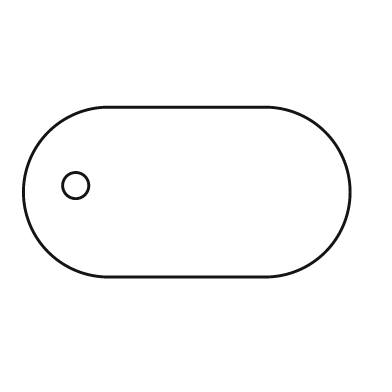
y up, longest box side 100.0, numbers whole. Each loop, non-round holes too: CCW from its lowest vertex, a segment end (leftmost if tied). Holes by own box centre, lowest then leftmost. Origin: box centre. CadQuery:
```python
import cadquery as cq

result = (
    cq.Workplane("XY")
    .moveTo(-24.0, -26.0)
    .lineTo(24.0, -26.0)
    .threePointArc((50.0, 0.0), (24.0, 26.0))
    .lineTo(-24.0, 26.0)
    .threePointArc((-50.0, 0.0), (-24.0, -26.0))
    .close()
    .moveTo(-34.0, 2.0)
    .circle(4.0)
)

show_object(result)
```